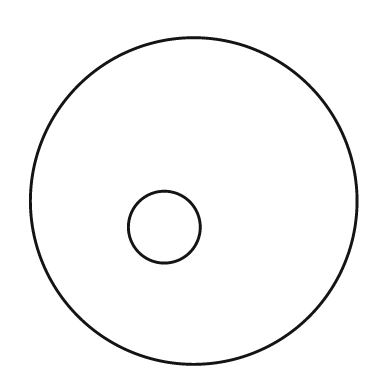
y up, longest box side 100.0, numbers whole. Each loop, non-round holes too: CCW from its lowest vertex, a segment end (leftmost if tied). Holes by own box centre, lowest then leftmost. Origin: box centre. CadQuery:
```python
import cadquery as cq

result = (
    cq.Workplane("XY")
    .moveTo(0.0, 0.0)
    .circle(50.0)
    .moveTo(-9.0, -8.0)
    .circle(11.0)
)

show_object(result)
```